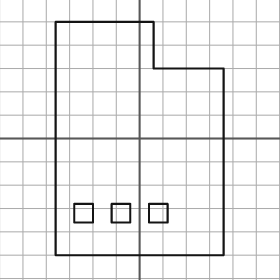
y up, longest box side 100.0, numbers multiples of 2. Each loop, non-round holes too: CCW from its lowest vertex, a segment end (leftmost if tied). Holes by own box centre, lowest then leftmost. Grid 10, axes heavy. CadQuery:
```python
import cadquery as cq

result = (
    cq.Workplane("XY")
    .moveTo(-36.0, -50.0)
    .lineTo(36.0, -50.0)
    .lineTo(36.0, 30.0)
    .lineTo(6.0, 30.0)
    .lineTo(6.0, 50.0)
    .lineTo(-36.0, 50.0)
    .close()
    .moveTo(-28.0, -36.0)
    .lineTo(-20.0, -36.0)
    .lineTo(-20.0, -28.0)
    .lineTo(-28.0, -28.0)
    .close()
    .moveTo(-12.0, -36.0)
    .lineTo(-4.0, -36.0)
    .lineTo(-4.0, -28.0)
    .lineTo(-12.0, -28.0)
    .close()
    .moveTo(4.0, -36.0)
    .lineTo(12.0, -36.0)
    .lineTo(12.0, -28.0)
    .lineTo(4.0, -28.0)
    .close()
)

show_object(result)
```